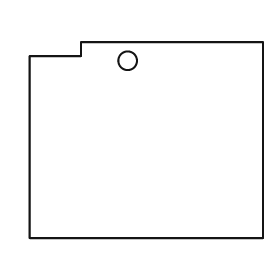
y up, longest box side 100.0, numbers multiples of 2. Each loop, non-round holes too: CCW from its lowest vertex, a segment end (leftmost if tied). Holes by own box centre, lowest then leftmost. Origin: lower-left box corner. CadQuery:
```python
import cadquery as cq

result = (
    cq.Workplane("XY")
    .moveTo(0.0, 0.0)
    .lineTo(100.0, 0.0)
    .lineTo(100.0, 84.0)
    .lineTo(22.0, 84.0)
    .lineTo(22.0, 78.0)
    .lineTo(0.0, 78.0)
    .close()
    .moveTo(42.0, 76.0)
    .circle(4.0)
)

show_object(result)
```